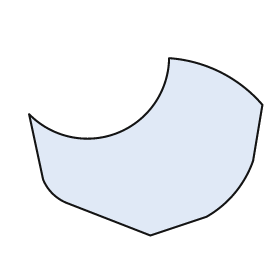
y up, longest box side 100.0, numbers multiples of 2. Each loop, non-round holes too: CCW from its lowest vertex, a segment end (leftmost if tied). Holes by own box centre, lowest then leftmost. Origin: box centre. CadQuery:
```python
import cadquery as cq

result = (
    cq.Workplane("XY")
    .moveTo(2.0, -38.0)
    .lineTo(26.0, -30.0)
    .threePointArc((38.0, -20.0), (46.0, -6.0))
    .lineTo(50.0, 18.0)
    .threePointArc((32.0, 32.0), (10.0, 38.0))
    .threePointArc((-12.0, 6.0), (-50.0, 14.0))
    .lineTo(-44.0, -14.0)
    .threePointArc((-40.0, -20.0), (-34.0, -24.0))
    .close()
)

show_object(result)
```